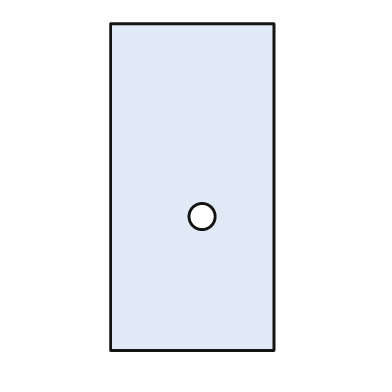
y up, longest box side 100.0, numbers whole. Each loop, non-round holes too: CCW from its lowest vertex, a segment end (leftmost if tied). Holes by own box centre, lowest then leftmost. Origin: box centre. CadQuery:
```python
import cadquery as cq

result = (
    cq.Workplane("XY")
    .moveTo(-25.0, -50.0)
    .lineTo(25.0, -50.0)
    .lineTo(25.0, 50.0)
    .lineTo(-25.0, 50.0)
    .close()
    .moveTo(3.0, -9.0)
    .circle(4.0)
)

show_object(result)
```